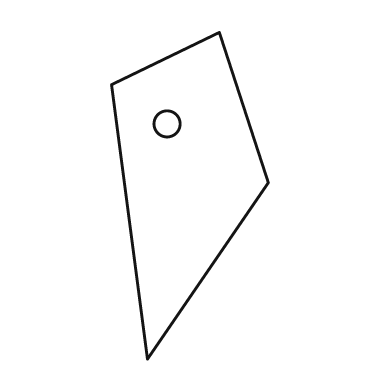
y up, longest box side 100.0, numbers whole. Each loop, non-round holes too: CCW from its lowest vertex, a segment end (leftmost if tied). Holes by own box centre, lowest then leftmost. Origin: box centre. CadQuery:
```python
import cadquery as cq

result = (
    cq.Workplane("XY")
    .moveTo(-13.0, -50.0)
    .lineTo(24.0, 4.0)
    .lineTo(9.0, 50.0)
    .lineTo(-24.0, 34.0)
    .close()
    .moveTo(-7.0, 22.0)
    .circle(4.0)
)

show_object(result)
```